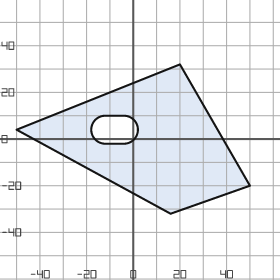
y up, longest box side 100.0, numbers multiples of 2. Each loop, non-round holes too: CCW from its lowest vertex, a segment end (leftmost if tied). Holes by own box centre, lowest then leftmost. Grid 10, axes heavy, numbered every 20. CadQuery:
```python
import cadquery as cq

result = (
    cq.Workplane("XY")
    .moveTo(16.0, -32.0)
    .lineTo(50.0, -20.0)
    .lineTo(20.0, 32.0)
    .lineTo(-50.0, 4.0)
    .close()
    .moveTo(-12.0, -2.0)
    .lineTo(-4.0, -2.0)
    .threePointArc((2.0, 4.0), (-4.0, 10.0))
    .lineTo(-12.0, 10.0)
    .threePointArc((-18.0, 4.0), (-12.0, -2.0))
    .close()
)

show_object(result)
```